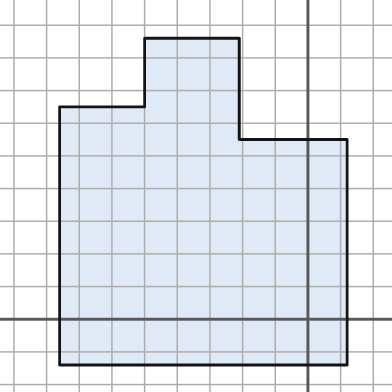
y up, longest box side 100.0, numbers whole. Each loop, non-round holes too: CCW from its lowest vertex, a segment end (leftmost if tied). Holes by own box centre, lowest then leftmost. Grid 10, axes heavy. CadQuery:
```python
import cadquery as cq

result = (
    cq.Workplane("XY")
    .moveTo(-76.0, -14.0)
    .lineTo(12.0, -14.0)
    .lineTo(12.0, 55.0)
    .lineTo(-21.0, 55.0)
    .lineTo(-21.0, 86.0)
    .lineTo(-50.0, 86.0)
    .lineTo(-50.0, 65.0)
    .lineTo(-76.0, 65.0)
    .close()
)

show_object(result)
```